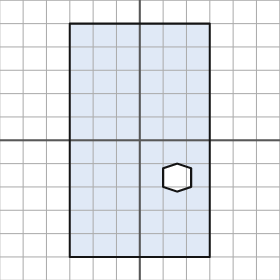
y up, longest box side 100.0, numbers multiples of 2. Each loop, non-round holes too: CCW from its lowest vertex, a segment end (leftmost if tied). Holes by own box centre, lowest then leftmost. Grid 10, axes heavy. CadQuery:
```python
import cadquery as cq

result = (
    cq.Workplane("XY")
    .moveTo(-30.0, -50.0)
    .lineTo(30.0, -50.0)
    .lineTo(30.0, 50.0)
    .lineTo(-30.0, 50.0)
    .close()
    .moveTo(16.0, -22.0)
    .lineTo(22.0, -20.0)
    .lineTo(22.0, -12.0)
    .lineTo(16.0, -10.0)
    .lineTo(10.0, -12.0)
    .lineTo(10.0, -20.0)
    .close()
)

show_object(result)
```